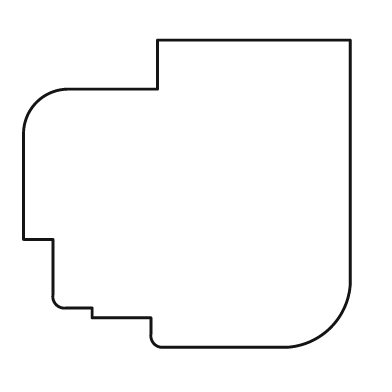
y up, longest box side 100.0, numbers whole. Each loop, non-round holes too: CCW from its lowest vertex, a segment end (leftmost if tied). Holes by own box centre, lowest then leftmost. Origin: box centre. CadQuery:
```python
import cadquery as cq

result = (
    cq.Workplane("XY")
    .moveTo(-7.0, -47.0)
    .lineTo(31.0, -47.0)
    .threePointArc((44.0, -41.0), (50.0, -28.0))
    .lineTo(50.0, 47.0)
    .lineTo(-9.0, 47.0)
    .lineTo(-9.0, 32.0)
    .lineTo(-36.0, 32.0)
    .threePointArc((-46.0, 28.0), (-50.0, 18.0))
    .lineTo(-50.0, -14.0)
    .lineTo(-41.0, -14.0)
    .lineTo(-41.0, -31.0)
    .threePointArc((-40.0, -34.0), (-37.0, -35.0))
    .lineTo(-29.0, -35.0)
    .lineTo(-29.0, -38.0)
    .lineTo(-11.0, -38.0)
    .lineTo(-11.0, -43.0)
    .threePointArc((-10.0, -46.0), (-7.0, -47.0))
    .close()
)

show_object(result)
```